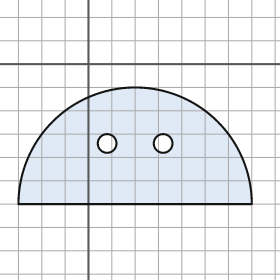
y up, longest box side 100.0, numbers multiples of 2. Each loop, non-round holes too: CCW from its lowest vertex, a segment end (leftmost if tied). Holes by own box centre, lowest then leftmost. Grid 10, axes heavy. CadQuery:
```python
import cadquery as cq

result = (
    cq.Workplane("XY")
    .moveTo(-30.0, -60.0)
    .lineTo(70.0, -60.0)
    .threePointArc((20.0, -10.0), (-30.0, -60.0))
    .close()
    .moveTo(8.0, -34.0)
    .circle(4.0)
    .moveTo(32.0, -34.0)
    .circle(4.0)
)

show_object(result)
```